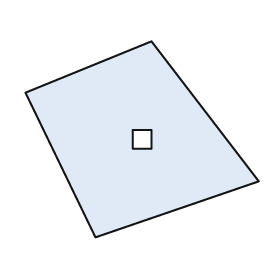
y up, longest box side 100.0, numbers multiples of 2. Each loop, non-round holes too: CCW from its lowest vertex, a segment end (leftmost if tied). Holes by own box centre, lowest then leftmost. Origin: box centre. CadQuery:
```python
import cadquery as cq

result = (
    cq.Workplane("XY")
    .moveTo(-20.0, -42.0)
    .lineTo(50.0, -18.0)
    .lineTo(4.0, 42.0)
    .lineTo(-50.0, 20.0)
    .close()
    .moveTo(-4.0, -4.0)
    .lineTo(4.0, -4.0)
    .lineTo(4.0, 4.0)
    .lineTo(-4.0, 4.0)
    .close()
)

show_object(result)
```